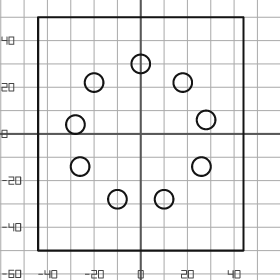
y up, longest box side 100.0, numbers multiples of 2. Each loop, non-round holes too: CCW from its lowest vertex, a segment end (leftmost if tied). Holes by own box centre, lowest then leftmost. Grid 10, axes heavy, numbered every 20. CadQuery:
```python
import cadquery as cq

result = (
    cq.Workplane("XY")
    .moveTo(-44.0, -50.0)
    .lineTo(44.0, -50.0)
    .lineTo(44.0, 50.0)
    .lineTo(-44.0, 50.0)
    .close()
    .moveTo(-10.0, -28.0)
    .circle(4.0)
    .moveTo(10.0, -28.0)
    .circle(4.0)
    .moveTo(-26.0, -14.0)
    .circle(4.0)
    .moveTo(26.0, -14.0)
    .circle(4.0)
    .moveTo(-28.0, 4.0)
    .circle(4.0)
    .moveTo(28.0, 6.0)
    .circle(4.0)
    .moveTo(-20.0, 22.0)
    .circle(4.0)
    .moveTo(18.0, 22.0)
    .circle(4.0)
    .moveTo(0.0, 30.0)
    .circle(4.0)
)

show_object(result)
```